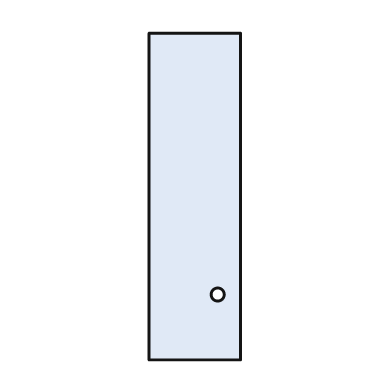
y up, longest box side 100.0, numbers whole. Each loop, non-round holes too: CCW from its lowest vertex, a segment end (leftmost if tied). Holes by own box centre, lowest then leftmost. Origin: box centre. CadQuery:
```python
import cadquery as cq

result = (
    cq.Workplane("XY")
    .moveTo(-14.0, -50.0)
    .lineTo(14.0, -50.0)
    .lineTo(14.0, 50.0)
    .lineTo(-14.0, 50.0)
    .close()
    .moveTo(7.0, -30.0)
    .circle(2.0)
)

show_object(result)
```